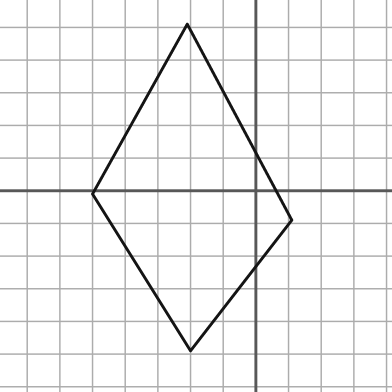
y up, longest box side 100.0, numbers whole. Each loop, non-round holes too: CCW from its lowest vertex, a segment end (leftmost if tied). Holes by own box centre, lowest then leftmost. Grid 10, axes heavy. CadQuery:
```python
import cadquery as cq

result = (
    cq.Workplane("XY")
    .moveTo(-20.0, -49.0)
    .lineTo(11.0, -9.0)
    .lineTo(-21.0, 51.0)
    .lineTo(-50.0, -1.0)
    .close()
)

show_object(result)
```